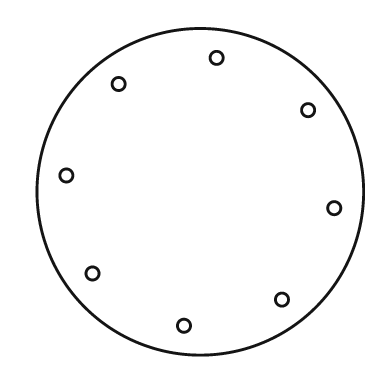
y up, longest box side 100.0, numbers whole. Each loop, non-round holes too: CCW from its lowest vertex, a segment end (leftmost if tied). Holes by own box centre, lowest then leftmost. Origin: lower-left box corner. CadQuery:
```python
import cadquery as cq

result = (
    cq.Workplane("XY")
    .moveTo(50.0, 50.0)
    .circle(50.0)
    .moveTo(45.0, 9.0)
    .circle(2.0)
    .moveTo(75.0, 17.0)
    .circle(2.0)
    .moveTo(17.0, 25.0)
    .circle(2.0)
    .moveTo(91.0, 45.0)
    .circle(2.0)
    .moveTo(9.0, 55.0)
    .circle(2.0)
    .moveTo(83.0, 75.0)
    .circle(2.0)
    .moveTo(25.0, 83.0)
    .circle(2.0)
    .moveTo(55.0, 91.0)
    .circle(2.0)
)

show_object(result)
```